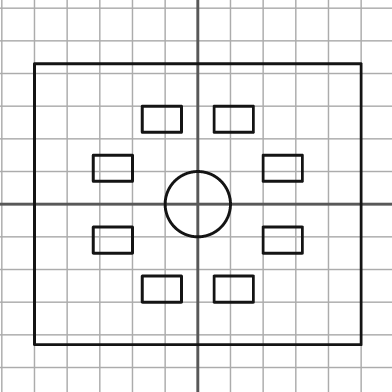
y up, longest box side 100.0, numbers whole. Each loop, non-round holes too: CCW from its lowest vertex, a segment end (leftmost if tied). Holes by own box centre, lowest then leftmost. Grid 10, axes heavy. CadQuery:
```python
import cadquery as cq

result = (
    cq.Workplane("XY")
    .moveTo(-50.0, -43.0)
    .lineTo(50.0, -43.0)
    .lineTo(50.0, 43.0)
    .lineTo(-50.0, 43.0)
    .close()
    .moveTo(-17.0, -30.0)
    .lineTo(-5.0, -30.0)
    .lineTo(-5.0, -22.0)
    .lineTo(-17.0, -22.0)
    .close()
    .moveTo(5.0, -30.0)
    .lineTo(17.0, -30.0)
    .lineTo(17.0, -22.0)
    .lineTo(5.0, -22.0)
    .close()
    .moveTo(-32.0, -15.0)
    .lineTo(-20.0, -15.0)
    .lineTo(-20.0, -7.0)
    .lineTo(-32.0, -7.0)
    .close()
    .moveTo(20.0, -15.0)
    .lineTo(32.0, -15.0)
    .lineTo(32.0, -7.0)
    .lineTo(20.0, -7.0)
    .close()
    .moveTo(0.0, 0.0)
    .circle(10.0)
    .moveTo(-32.0, 7.0)
    .lineTo(-20.0, 7.0)
    .lineTo(-20.0, 15.0)
    .lineTo(-32.0, 15.0)
    .close()
    .moveTo(20.0, 7.0)
    .lineTo(32.0, 7.0)
    .lineTo(32.0, 15.0)
    .lineTo(20.0, 15.0)
    .close()
    .moveTo(-17.0, 22.0)
    .lineTo(-5.0, 22.0)
    .lineTo(-5.0, 30.0)
    .lineTo(-17.0, 30.0)
    .close()
    .moveTo(5.0, 22.0)
    .lineTo(17.0, 22.0)
    .lineTo(17.0, 30.0)
    .lineTo(5.0, 30.0)
    .close()
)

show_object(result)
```